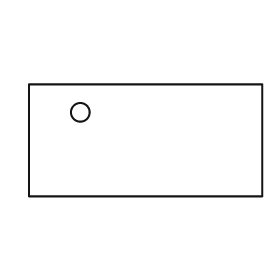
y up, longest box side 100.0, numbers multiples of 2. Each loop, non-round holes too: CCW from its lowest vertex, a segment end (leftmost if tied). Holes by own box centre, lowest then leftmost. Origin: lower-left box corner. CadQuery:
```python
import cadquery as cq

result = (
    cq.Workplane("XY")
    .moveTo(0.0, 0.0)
    .lineTo(100.0, 0.0)
    .lineTo(100.0, 48.0)
    .lineTo(0.0, 48.0)
    .close()
    .moveTo(22.0, 36.0)
    .circle(4.0)
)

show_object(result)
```